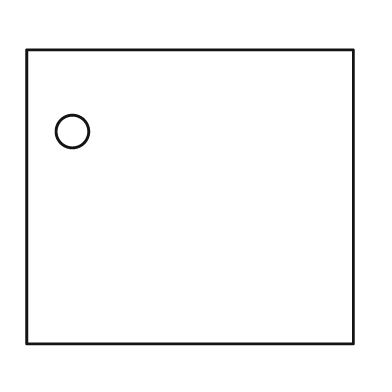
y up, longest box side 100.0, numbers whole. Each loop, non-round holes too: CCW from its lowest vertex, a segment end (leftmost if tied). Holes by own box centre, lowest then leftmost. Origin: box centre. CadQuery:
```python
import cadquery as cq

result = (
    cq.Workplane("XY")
    .moveTo(-50.0, -45.0)
    .lineTo(50.0, -45.0)
    .lineTo(50.0, 45.0)
    .lineTo(-50.0, 45.0)
    .close()
    .moveTo(-36.0, 20.0)
    .circle(5.0)
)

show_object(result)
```